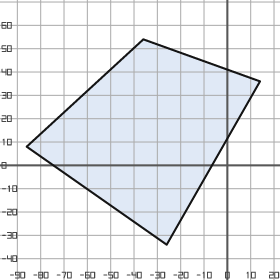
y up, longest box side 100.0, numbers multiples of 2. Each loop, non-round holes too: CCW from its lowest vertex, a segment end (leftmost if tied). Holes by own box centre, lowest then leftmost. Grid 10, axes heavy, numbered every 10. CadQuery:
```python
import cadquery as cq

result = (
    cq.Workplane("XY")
    .moveTo(-26.0, -34.0)
    .lineTo(14.0, 36.0)
    .lineTo(-36.0, 54.0)
    .lineTo(-86.0, 8.0)
    .close()
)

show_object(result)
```